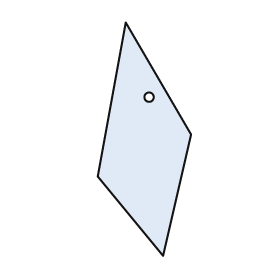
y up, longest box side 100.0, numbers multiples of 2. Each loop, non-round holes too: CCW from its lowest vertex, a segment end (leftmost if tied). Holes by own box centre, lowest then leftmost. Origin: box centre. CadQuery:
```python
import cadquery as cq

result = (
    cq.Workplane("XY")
    .moveTo(8.0, -50.0)
    .lineTo(20.0, 2.0)
    .lineTo(-8.0, 50.0)
    .lineTo(-20.0, -16.0)
    .close()
    .moveTo(2.0, 18.0)
    .circle(2.0)
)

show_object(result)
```